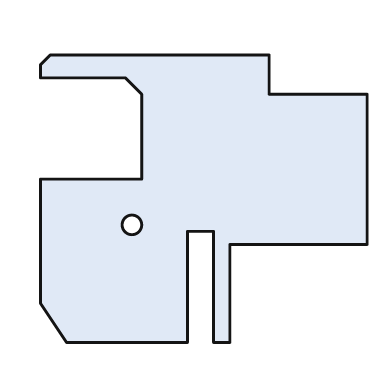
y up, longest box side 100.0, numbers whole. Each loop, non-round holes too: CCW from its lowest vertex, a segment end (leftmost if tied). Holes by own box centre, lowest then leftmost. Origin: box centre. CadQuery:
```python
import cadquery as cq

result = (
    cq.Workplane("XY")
    .moveTo(-42.0, -44.0)
    .lineTo(-5.0, -44.0)
    .lineTo(-5.0, -10.0)
    .lineTo(3.0, -10.0)
    .lineTo(3.0, -44.0)
    .lineTo(8.0, -44.0)
    .lineTo(8.0, -14.0)
    .lineTo(50.0, -14.0)
    .lineTo(50.0, 32.0)
    .lineTo(20.0, 32.0)
    .lineTo(20.0, 44.0)
    .lineTo(-47.0, 44.0)
    .lineTo(-50.0, 41.0)
    .lineTo(-50.0, 37.0)
    .lineTo(-24.0, 37.0)
    .lineTo(-19.0, 32.0)
    .lineTo(-19.0, 6.0)
    .lineTo(-50.0, 6.0)
    .lineTo(-50.0, -32.0)
    .close()
    .moveTo(-22.0, -8.0)
    .circle(3.0)
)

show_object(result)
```